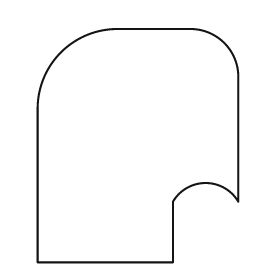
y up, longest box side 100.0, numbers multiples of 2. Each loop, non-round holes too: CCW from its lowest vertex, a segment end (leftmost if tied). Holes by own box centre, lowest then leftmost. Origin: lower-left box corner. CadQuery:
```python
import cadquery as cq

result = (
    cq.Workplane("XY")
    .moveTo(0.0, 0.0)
    .lineTo(58.0, 0.0)
    .lineTo(58.0, 26.0)
    .threePointArc((72.0, 34.0), (86.0, 26.0))
    .lineTo(86.0, 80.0)
    .threePointArc((80.0, 94.0), (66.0, 100.0))
    .lineTo(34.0, 100.0)
    .threePointArc((10.0, 90.0), (0.0, 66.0))
    .close()
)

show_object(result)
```